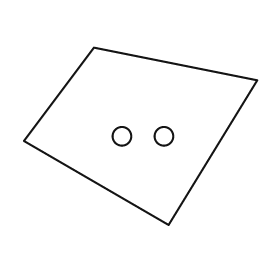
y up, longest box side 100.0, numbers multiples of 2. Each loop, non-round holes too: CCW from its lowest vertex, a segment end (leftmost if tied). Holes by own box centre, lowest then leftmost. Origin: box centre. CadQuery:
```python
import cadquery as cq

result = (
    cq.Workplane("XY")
    .moveTo(12.0, -38.0)
    .lineTo(50.0, 24.0)
    .lineTo(-20.0, 38.0)
    .lineTo(-50.0, -2.0)
    .close()
    .moveTo(-8.0, 0.0)
    .circle(4.0)
    .moveTo(10.0, 0.0)
    .circle(4.0)
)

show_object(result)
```